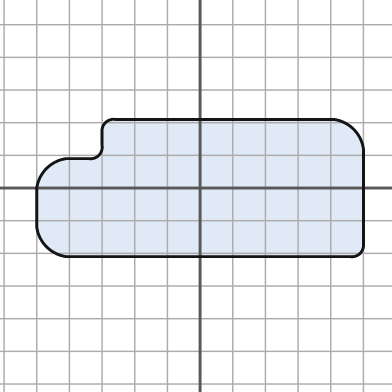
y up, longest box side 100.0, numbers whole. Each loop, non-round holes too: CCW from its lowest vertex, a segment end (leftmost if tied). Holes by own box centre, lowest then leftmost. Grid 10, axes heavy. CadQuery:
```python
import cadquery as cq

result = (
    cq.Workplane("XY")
    .moveTo(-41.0, -21.0)
    .lineTo(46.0, -21.0)
    .threePointArc((49.0, -20.0), (50.0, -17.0))
    .lineTo(50.0, 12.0)
    .threePointArc((47.0, 18.0), (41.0, 21.0))
    .lineTo(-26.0, 21.0)
    .threePointArc((-29.0, 20.0), (-30.0, 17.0))
    .lineTo(-30.0, 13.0)
    .threePointArc((-31.0, 10.0), (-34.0, 9.0))
    .lineTo(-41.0, 9.0)
    .threePointArc((-47.0, 6.0), (-50.0, 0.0))
    .lineTo(-50.0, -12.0)
    .threePointArc((-47.0, -18.0), (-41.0, -21.0))
    .close()
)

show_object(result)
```